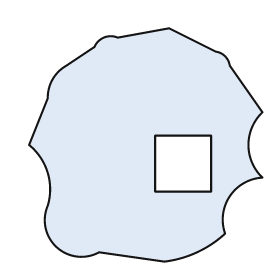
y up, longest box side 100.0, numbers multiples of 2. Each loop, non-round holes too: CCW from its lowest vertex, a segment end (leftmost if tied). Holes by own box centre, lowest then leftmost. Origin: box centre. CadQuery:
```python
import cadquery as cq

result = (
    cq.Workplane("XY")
    .moveTo(8.0, -50.0)
    .threePointArc((22.0, -46.0), (34.0, -38.0))
    .threePointArc((36.0, -22.0), (50.0, -14.0))
    .threePointArc((44.0, 0.0), (50.0, 14.0))
    .lineTo(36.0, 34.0)
    .threePointArc((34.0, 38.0), (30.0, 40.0))
    .lineTo(10.0, 50.0)
    .lineTo(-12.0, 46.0)
    .threePointArc((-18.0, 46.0), (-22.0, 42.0))
    .lineTo(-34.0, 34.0)
    .threePointArc((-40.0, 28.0), (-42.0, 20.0))
    .lineTo(-50.0, 0.0)
    .threePointArc((-42.0, -12.0), (-42.0, -26.0))
    .threePointArc((-38.0, -44.0), (-20.0, -46.0))
    .close()
    .moveTo(4.0, -20.0)
    .lineTo(28.0, -20.0)
    .lineTo(28.0, 4.0)
    .lineTo(4.0, 4.0)
    .close()
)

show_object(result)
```